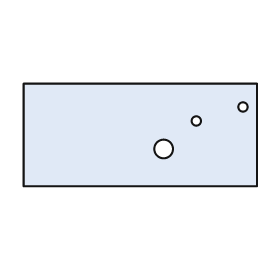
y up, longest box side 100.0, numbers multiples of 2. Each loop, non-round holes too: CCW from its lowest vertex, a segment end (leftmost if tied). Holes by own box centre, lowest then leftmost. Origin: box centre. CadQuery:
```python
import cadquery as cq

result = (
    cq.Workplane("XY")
    .moveTo(-50.0, -22.0)
    .lineTo(50.0, -22.0)
    .lineTo(50.0, 22.0)
    .lineTo(-50.0, 22.0)
    .close()
    .moveTo(10.0, -6.0)
    .circle(4.0)
    .moveTo(24.0, 6.0)
    .circle(2.0)
    .moveTo(44.0, 12.0)
    .circle(2.0)
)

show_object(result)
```